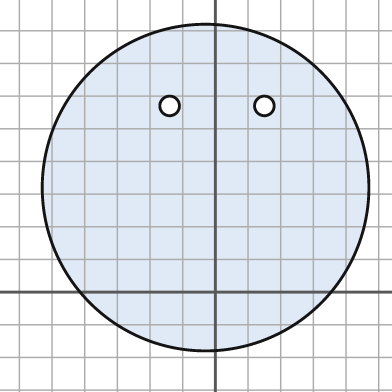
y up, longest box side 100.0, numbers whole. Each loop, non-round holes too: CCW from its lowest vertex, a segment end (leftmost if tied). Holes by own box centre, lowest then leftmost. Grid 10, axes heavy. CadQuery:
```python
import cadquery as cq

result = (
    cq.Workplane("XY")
    .moveTo(-3.0, 32.0)
    .circle(50.0)
    .moveTo(-14.0, 57.0)
    .circle(3.0)
    .moveTo(15.0, 57.0)
    .circle(3.0)
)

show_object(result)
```